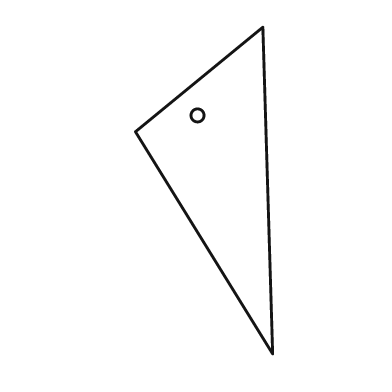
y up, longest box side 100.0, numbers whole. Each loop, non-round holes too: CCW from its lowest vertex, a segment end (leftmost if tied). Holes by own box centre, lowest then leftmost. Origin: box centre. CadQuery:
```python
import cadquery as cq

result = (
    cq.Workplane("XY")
    .moveTo(21.0, -50.0)
    .lineTo(18.0, 50.0)
    .lineTo(-21.0, 18.0)
    .close()
    .moveTo(-2.0, 23.0)
    .circle(2.0)
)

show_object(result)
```